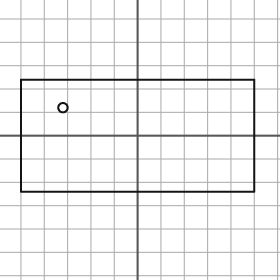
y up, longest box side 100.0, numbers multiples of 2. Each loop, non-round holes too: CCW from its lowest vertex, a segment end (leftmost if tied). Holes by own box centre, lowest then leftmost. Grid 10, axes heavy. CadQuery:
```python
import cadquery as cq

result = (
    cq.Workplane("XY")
    .moveTo(-50.0, -24.0)
    .lineTo(50.0, -24.0)
    .lineTo(50.0, 24.0)
    .lineTo(-50.0, 24.0)
    .close()
    .moveTo(-32.0, 12.0)
    .circle(2.0)
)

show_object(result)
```